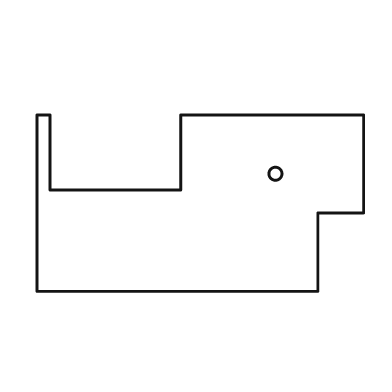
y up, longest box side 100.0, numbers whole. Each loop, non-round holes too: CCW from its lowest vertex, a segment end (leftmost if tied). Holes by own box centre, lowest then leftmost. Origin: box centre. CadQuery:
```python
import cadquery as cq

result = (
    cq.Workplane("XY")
    .moveTo(-50.0, -27.0)
    .lineTo(36.0, -27.0)
    .lineTo(36.0, -3.0)
    .lineTo(50.0, -3.0)
    .lineTo(50.0, 27.0)
    .lineTo(-6.0, 27.0)
    .lineTo(-6.0, 4.0)
    .lineTo(-46.0, 4.0)
    .lineTo(-46.0, 27.0)
    .lineTo(-50.0, 27.0)
    .close()
    .moveTo(23.0, 9.0)
    .circle(2.0)
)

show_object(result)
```